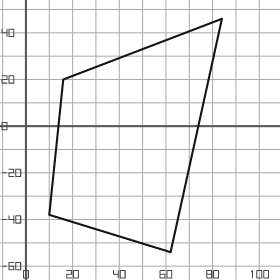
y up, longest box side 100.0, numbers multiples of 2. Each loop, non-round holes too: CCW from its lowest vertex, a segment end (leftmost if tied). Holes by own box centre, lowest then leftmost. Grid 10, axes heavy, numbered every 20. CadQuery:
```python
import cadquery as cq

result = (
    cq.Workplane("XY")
    .moveTo(62.0, -54.0)
    .lineTo(84.0, 46.0)
    .lineTo(16.0, 20.0)
    .lineTo(10.0, -38.0)
    .close()
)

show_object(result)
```